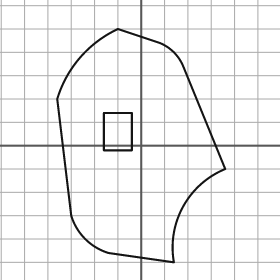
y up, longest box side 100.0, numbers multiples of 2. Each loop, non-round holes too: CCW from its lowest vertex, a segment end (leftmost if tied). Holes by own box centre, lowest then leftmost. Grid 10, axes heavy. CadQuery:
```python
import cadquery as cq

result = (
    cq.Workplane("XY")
    .moveTo(14.0, -50.0)
    .threePointArc((18.0, -26.0), (36.0, -10.0))
    .lineTo(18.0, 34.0)
    .threePointArc((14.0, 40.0), (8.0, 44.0))
    .lineTo(-10.0, 50.0)
    .threePointArc((-26.0, 38.0), (-36.0, 20.0))
    .lineTo(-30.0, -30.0)
    .threePointArc((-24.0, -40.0), (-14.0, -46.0))
    .close()
    .moveTo(-16.0, -2.0)
    .lineTo(-4.0, -2.0)
    .lineTo(-4.0, 14.0)
    .lineTo(-16.0, 14.0)
    .close()
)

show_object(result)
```